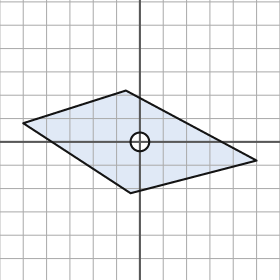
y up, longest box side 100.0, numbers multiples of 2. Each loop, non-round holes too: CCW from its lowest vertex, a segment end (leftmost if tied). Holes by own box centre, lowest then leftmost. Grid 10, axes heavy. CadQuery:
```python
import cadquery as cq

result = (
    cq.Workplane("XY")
    .moveTo(-4.0, -22.0)
    .lineTo(50.0, -8.0)
    .lineTo(-6.0, 22.0)
    .lineTo(-50.0, 8.0)
    .close()
    .moveTo(0.0, 0.0)
    .circle(4.0)
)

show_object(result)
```